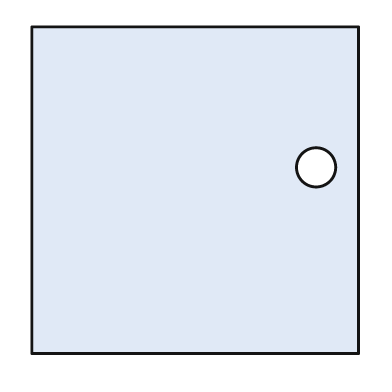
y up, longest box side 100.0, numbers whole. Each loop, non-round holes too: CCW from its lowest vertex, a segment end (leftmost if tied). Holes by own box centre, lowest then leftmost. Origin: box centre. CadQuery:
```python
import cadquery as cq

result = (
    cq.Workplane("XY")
    .moveTo(-50.0, -50.0)
    .lineTo(50.0, -50.0)
    .lineTo(50.0, 50.0)
    .lineTo(-50.0, 50.0)
    .close()
    .moveTo(37.0, 7.0)
    .circle(6.0)
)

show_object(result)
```